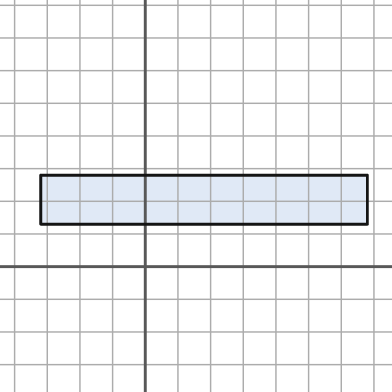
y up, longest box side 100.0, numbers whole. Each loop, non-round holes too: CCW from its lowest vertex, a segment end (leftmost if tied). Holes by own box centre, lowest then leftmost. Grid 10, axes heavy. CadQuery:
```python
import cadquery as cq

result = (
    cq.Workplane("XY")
    .moveTo(-32.0, 13.0)
    .lineTo(68.0, 13.0)
    .lineTo(68.0, 28.0)
    .lineTo(-32.0, 28.0)
    .close()
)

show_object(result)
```